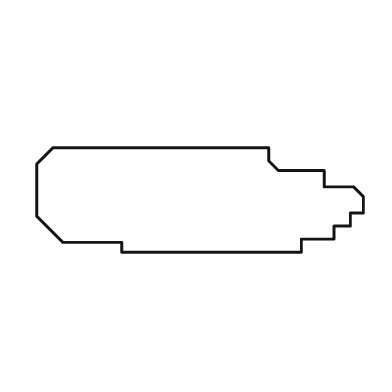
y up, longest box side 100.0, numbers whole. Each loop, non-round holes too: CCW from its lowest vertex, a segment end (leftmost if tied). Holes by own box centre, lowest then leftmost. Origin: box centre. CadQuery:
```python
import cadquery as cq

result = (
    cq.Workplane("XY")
    .moveTo(-24.0, -16.0)
    .lineTo(31.0, -16.0)
    .lineTo(31.0, -12.0)
    .lineTo(41.0, -12.0)
    .lineTo(41.0, -8.0)
    .lineTo(46.0, -8.0)
    .lineTo(46.0, -4.0)
    .lineTo(50.0, -4.0)
    .lineTo(50.0, 1.0)
    .lineTo(47.0, 4.0)
    .lineTo(38.0, 4.0)
    .lineTo(38.0, 9.0)
    .lineTo(24.0, 9.0)
    .lineTo(21.0, 12.0)
    .lineTo(21.0, 16.0)
    .lineTo(-45.0, 16.0)
    .lineTo(-50.0, 11.0)
    .lineTo(-50.0, -5.0)
    .lineTo(-42.0, -13.0)
    .lineTo(-24.0, -13.0)
    .close()
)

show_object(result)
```